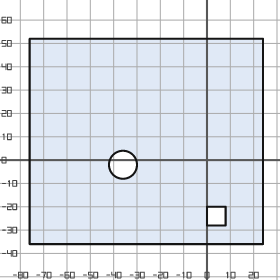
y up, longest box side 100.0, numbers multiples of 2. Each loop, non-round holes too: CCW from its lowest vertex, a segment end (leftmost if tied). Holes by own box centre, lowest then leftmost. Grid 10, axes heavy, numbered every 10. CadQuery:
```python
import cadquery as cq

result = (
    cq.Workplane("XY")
    .moveTo(-76.0, -36.0)
    .lineTo(24.0, -36.0)
    .lineTo(24.0, 52.0)
    .lineTo(-76.0, 52.0)
    .close()
    .moveTo(0.0, -28.0)
    .lineTo(8.0, -28.0)
    .lineTo(8.0, -20.0)
    .lineTo(0.0, -20.0)
    .close()
    .moveTo(-36.0, -2.0)
    .circle(6.0)
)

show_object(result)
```